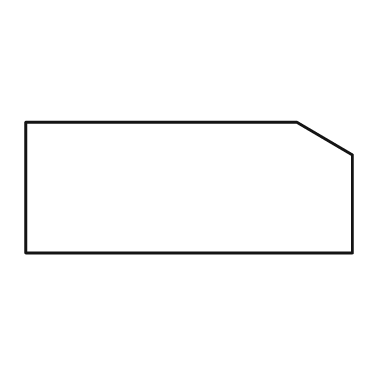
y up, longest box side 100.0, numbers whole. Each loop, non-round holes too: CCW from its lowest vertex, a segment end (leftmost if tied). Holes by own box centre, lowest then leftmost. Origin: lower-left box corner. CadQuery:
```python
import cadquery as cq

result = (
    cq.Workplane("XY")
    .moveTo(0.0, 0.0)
    .lineTo(100.0, 0.0)
    .lineTo(100.0, 30.0)
    .lineTo(83.0, 40.0)
    .lineTo(0.0, 40.0)
    .close()
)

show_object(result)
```